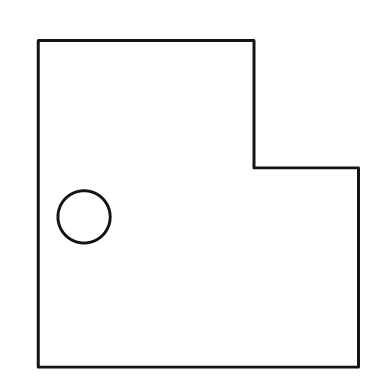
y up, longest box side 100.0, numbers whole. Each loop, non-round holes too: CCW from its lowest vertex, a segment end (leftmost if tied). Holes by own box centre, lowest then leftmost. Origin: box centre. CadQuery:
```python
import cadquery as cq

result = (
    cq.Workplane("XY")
    .moveTo(-49.0, -50.0)
    .lineTo(49.0, -50.0)
    .lineTo(49.0, 11.0)
    .lineTo(17.0, 11.0)
    .lineTo(17.0, 50.0)
    .lineTo(-49.0, 50.0)
    .close()
    .moveTo(-35.0, -4.0)
    .circle(8.0)
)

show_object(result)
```